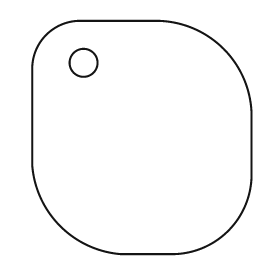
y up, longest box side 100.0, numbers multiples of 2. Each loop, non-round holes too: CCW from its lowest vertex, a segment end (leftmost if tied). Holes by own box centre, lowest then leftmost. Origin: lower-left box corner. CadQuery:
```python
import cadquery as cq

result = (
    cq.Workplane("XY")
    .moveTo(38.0, 0.0)
    .lineTo(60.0, 0.0)
    .threePointArc((84.0, 10.0), (94.0, 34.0))
    .lineTo(94.0, 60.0)
    .threePointArc((82.0, 88.0), (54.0, 100.0))
    .lineTo(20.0, 100.0)
    .threePointArc((6.0, 94.0), (0.0, 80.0))
    .lineTo(0.0, 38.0)
    .threePointArc((12.0, 12.0), (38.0, 0.0))
    .close()
    .moveTo(22.0, 82.0)
    .circle(6.0)
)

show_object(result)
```